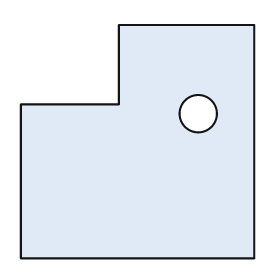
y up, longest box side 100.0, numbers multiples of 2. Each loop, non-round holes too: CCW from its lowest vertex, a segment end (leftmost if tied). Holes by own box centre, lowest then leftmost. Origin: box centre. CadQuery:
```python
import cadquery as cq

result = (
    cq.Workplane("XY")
    .moveTo(-50.0, -50.0)
    .lineTo(50.0, -50.0)
    .lineTo(50.0, 50.0)
    .lineTo(-8.0, 50.0)
    .lineTo(-8.0, 16.0)
    .lineTo(-50.0, 16.0)
    .close()
    .moveTo(26.0, 12.0)
    .circle(8.0)
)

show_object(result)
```